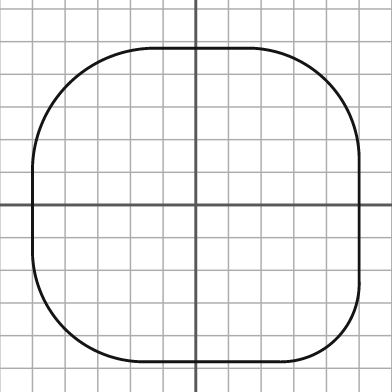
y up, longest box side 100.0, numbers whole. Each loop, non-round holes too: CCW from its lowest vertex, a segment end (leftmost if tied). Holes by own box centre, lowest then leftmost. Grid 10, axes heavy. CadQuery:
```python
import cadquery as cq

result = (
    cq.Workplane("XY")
    .moveTo(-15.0, -48.0)
    .lineTo(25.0, -48.0)
    .threePointArc((43.0, -41.0), (50.0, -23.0))
    .lineTo(50.0, 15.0)
    .threePointArc((40.0, 38.0), (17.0, 48.0))
    .lineTo(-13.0, 48.0)
    .threePointArc((-39.0, 37.0), (-50.0, 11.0))
    .lineTo(-50.0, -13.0)
    .threePointArc((-40.0, -38.0), (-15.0, -48.0))
    .close()
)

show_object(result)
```